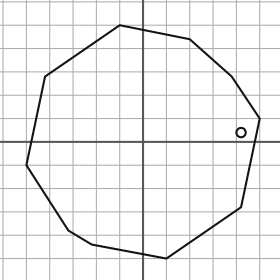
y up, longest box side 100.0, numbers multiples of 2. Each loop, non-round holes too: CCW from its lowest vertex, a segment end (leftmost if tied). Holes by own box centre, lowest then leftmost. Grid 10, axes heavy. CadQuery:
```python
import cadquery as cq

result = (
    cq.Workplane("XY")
    .moveTo(10.0, -50.0)
    .lineTo(42.0, -28.0)
    .lineTo(50.0, 10.0)
    .lineTo(38.0, 28.0)
    .lineTo(20.0, 44.0)
    .lineTo(-10.0, 50.0)
    .lineTo(-42.0, 28.0)
    .lineTo(-50.0, -10.0)
    .lineTo(-32.0, -38.0)
    .lineTo(-22.0, -44.0)
    .close()
    .moveTo(42.0, 4.0)
    .circle(2.0)
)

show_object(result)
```